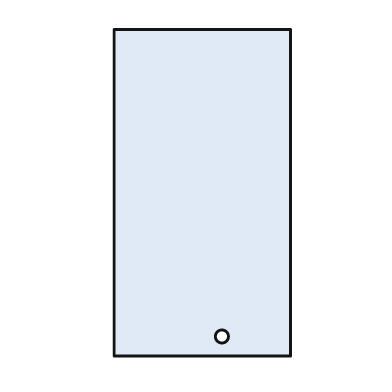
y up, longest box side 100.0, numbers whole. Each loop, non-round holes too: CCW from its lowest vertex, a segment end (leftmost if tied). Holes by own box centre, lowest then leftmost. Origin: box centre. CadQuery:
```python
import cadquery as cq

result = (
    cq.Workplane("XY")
    .moveTo(-27.0, -50.0)
    .lineTo(27.0, -50.0)
    .lineTo(27.0, 50.0)
    .lineTo(-27.0, 50.0)
    .close()
    .moveTo(6.0, -44.0)
    .circle(2.0)
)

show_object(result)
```